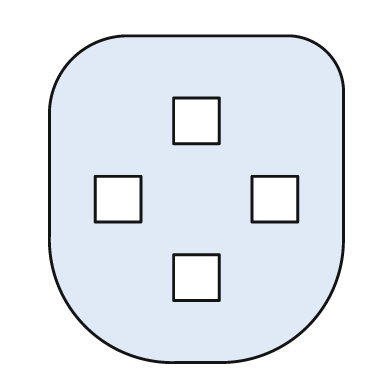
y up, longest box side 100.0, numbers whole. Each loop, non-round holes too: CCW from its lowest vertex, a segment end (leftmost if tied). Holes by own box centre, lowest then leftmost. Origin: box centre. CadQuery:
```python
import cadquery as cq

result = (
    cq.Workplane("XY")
    .moveTo(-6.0, -50.0)
    .lineTo(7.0, -50.0)
    .threePointArc((34.0, -39.0), (45.0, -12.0))
    .lineTo(45.0, 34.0)
    .threePointArc((40.0, 45.0), (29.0, 50.0))
    .lineTo(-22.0, 50.0)
    .threePointArc((-38.0, 43.0), (-45.0, 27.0))
    .lineTo(-45.0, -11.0)
    .threePointArc((-34.0, -39.0), (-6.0, -50.0))
    .close()
    .moveTo(-7.0, -31.0)
    .lineTo(7.0, -31.0)
    .lineTo(7.0, -17.0)
    .lineTo(-7.0, -17.0)
    .close()
    .moveTo(-31.0, -7.0)
    .lineTo(-17.0, -7.0)
    .lineTo(-17.0, 7.0)
    .lineTo(-31.0, 7.0)
    .close()
    .moveTo(17.0, -7.0)
    .lineTo(31.0, -7.0)
    .lineTo(31.0, 7.0)
    .lineTo(17.0, 7.0)
    .close()
    .moveTo(-7.0, 17.0)
    .lineTo(7.0, 17.0)
    .lineTo(7.0, 31.0)
    .lineTo(-7.0, 31.0)
    .close()
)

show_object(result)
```